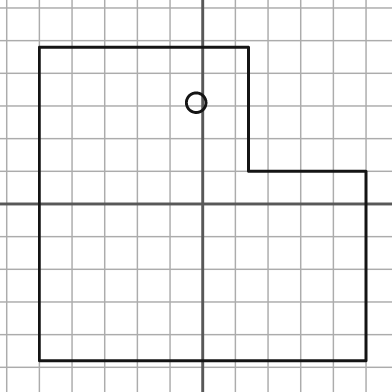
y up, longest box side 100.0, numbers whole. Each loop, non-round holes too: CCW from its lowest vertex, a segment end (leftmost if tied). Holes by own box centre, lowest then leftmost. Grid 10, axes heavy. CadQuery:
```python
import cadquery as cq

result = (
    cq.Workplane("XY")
    .moveTo(-50.0, -48.0)
    .lineTo(50.0, -48.0)
    .lineTo(50.0, 10.0)
    .lineTo(14.0, 10.0)
    .lineTo(14.0, 48.0)
    .lineTo(-50.0, 48.0)
    .close()
    .moveTo(-2.0, 31.0)
    .circle(3.0)
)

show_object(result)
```